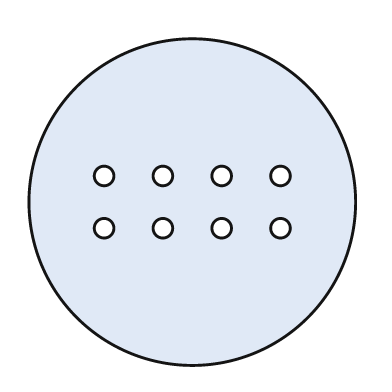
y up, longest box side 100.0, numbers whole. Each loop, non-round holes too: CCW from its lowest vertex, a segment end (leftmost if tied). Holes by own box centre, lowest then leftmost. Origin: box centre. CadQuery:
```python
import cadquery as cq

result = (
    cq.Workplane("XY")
    .moveTo(0.0, 0.0)
    .circle(50.0)
    .moveTo(-27.0, -8.0)
    .circle(3.0)
    .moveTo(-9.0, -8.0)
    .circle(3.0)
    .moveTo(9.0, -8.0)
    .circle(3.0)
    .moveTo(27.0, -8.0)
    .circle(3.0)
    .moveTo(-27.0, 8.0)
    .circle(3.0)
    .moveTo(-9.0, 8.0)
    .circle(3.0)
    .moveTo(9.0, 8.0)
    .circle(3.0)
    .moveTo(27.0, 8.0)
    .circle(3.0)
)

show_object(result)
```